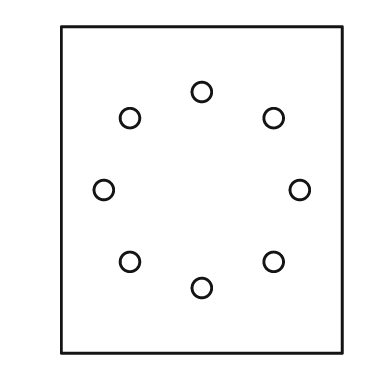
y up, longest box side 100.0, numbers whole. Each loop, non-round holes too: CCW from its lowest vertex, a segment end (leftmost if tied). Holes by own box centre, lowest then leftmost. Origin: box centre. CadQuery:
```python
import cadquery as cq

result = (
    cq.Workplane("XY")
    .moveTo(-43.0, -50.0)
    .lineTo(43.0, -50.0)
    .lineTo(43.0, 50.0)
    .lineTo(-43.0, 50.0)
    .close()
    .moveTo(0.0, -30.0)
    .circle(3.0)
    .moveTo(-22.0, -22.0)
    .circle(3.0)
    .moveTo(22.0, -22.0)
    .circle(3.0)
    .moveTo(-30.0, 0.0)
    .circle(3.0)
    .moveTo(30.0, 0.0)
    .circle(3.0)
    .moveTo(-22.0, 22.0)
    .circle(3.0)
    .moveTo(22.0, 22.0)
    .circle(3.0)
    .moveTo(0.0, 30.0)
    .circle(3.0)
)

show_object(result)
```